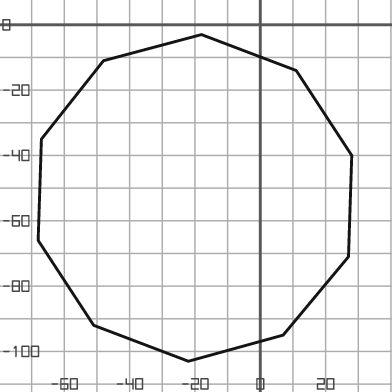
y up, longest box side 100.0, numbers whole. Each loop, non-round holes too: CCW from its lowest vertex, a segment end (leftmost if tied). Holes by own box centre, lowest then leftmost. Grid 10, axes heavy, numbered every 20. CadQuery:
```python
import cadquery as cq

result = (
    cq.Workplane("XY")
    .moveTo(-22.0, -103.0)
    .lineTo(7.0, -95.0)
    .lineTo(27.0, -71.0)
    .lineTo(28.0, -40.0)
    .lineTo(11.0, -14.0)
    .lineTo(-18.0, -3.0)
    .lineTo(-48.0, -11.0)
    .lineTo(-67.0, -35.0)
    .lineTo(-68.0, -66.0)
    .lineTo(-51.0, -92.0)
    .close()
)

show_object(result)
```